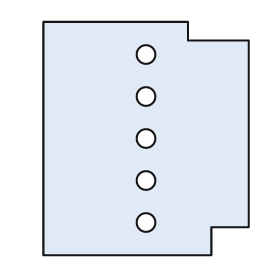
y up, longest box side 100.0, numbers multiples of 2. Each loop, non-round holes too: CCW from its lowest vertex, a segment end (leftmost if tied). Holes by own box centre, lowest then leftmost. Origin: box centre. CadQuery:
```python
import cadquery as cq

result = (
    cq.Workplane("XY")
    .moveTo(-44.0, -50.0)
    .lineTo(28.0, -50.0)
    .lineTo(28.0, -38.0)
    .lineTo(44.0, -38.0)
    .lineTo(44.0, 42.0)
    .lineTo(18.0, 42.0)
    .lineTo(18.0, 50.0)
    .lineTo(-44.0, 50.0)
    .close()
    .moveTo(0.0, -36.0)
    .circle(4.0)
    .moveTo(0.0, -18.0)
    .circle(4.0)
    .moveTo(0.0, 0.0)
    .circle(4.0)
    .moveTo(0.0, 18.0)
    .circle(4.0)
    .moveTo(0.0, 36.0)
    .circle(4.0)
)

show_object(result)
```